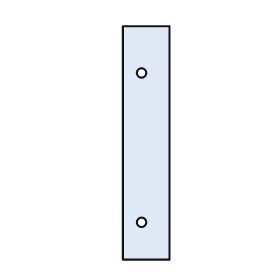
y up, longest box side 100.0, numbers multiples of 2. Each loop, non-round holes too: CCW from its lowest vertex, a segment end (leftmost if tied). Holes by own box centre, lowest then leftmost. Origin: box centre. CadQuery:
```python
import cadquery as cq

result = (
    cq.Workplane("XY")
    .moveTo(-10.0, -50.0)
    .lineTo(10.0, -50.0)
    .lineTo(10.0, 50.0)
    .lineTo(-10.0, 50.0)
    .close()
    .moveTo(-2.0, -34.0)
    .circle(2.0)
    .moveTo(-2.0, 30.0)
    .circle(2.0)
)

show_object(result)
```